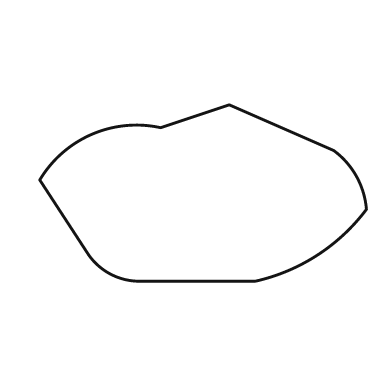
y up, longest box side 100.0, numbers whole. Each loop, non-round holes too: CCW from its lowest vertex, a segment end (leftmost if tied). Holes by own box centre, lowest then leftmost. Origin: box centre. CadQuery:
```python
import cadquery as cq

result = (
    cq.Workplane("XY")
    .moveTo(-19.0, -27.0)
    .lineTo(16.0, -27.0)
    .threePointArc((35.0, -19.0), (50.0, -5.0))
    .threePointArc((47.0, 5.0), (40.0, 13.0))
    .lineTo(8.0, 27.0)
    .lineTo(-13.0, 20.0)
    .threePointArc((-34.0, 18.0), (-50.0, 4.0))
    .lineTo(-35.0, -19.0)
    .threePointArc((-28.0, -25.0), (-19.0, -27.0))
    .close()
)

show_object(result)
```